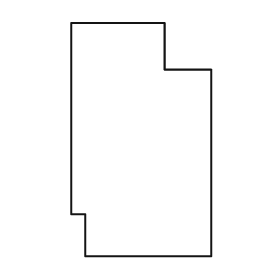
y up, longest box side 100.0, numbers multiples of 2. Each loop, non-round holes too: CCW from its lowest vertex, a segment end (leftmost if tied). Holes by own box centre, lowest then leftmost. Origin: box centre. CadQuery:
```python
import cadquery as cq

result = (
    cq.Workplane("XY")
    .moveTo(-24.0, -50.0)
    .lineTo(30.0, -50.0)
    .lineTo(30.0, 30.0)
    .lineTo(10.0, 30.0)
    .lineTo(10.0, 50.0)
    .lineTo(-30.0, 50.0)
    .lineTo(-30.0, -32.0)
    .lineTo(-24.0, -32.0)
    .close()
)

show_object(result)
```